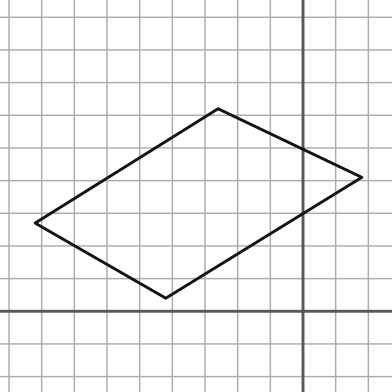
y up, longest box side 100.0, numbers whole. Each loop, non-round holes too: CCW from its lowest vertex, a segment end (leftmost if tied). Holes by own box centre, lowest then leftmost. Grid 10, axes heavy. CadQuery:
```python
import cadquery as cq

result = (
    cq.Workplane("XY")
    .moveTo(-42.0, 4.0)
    .lineTo(18.0, 41.0)
    .lineTo(-26.0, 62.0)
    .lineTo(-82.0, 27.0)
    .close()
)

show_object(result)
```